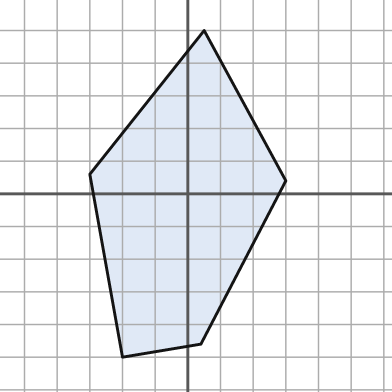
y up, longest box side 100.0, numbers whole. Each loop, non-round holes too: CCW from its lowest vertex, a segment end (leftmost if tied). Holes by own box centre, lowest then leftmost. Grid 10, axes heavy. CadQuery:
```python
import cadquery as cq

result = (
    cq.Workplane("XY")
    .moveTo(-20.0, -50.0)
    .lineTo(4.0, -46.0)
    .lineTo(30.0, 4.0)
    .lineTo(5.0, 50.0)
    .lineTo(-30.0, 6.0)
    .close()
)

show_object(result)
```